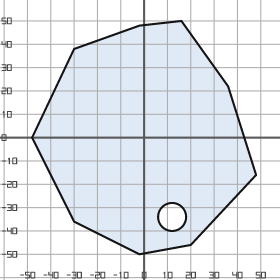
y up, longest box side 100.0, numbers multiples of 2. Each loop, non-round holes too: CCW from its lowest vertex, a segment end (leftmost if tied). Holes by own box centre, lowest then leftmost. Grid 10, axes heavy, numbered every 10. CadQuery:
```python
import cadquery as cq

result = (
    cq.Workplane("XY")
    .moveTo(-2.0, -50.0)
    .lineTo(20.0, -46.0)
    .lineTo(48.0, -16.0)
    .lineTo(36.0, 22.0)
    .lineTo(16.0, 50.0)
    .lineTo(-2.0, 48.0)
    .lineTo(-30.0, 38.0)
    .lineTo(-48.0, 0.0)
    .lineTo(-30.0, -36.0)
    .close()
    .moveTo(12.0, -34.0)
    .circle(6.0)
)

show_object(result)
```